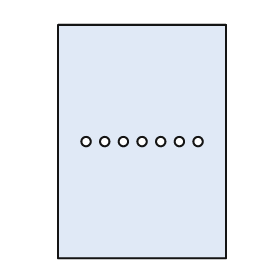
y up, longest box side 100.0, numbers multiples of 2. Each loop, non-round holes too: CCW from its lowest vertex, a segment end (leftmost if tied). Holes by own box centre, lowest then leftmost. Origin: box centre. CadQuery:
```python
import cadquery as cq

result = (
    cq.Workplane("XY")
    .moveTo(-36.0, -50.0)
    .lineTo(36.0, -50.0)
    .lineTo(36.0, 50.0)
    .lineTo(-36.0, 50.0)
    .close()
    .moveTo(-24.0, 0.0)
    .circle(2.0)
    .moveTo(-16.0, 0.0)
    .circle(2.0)
    .moveTo(-8.0, 0.0)
    .circle(2.0)
    .moveTo(0.0, 0.0)
    .circle(2.0)
    .moveTo(8.0, 0.0)
    .circle(2.0)
    .moveTo(16.0, 0.0)
    .circle(2.0)
    .moveTo(24.0, 0.0)
    .circle(2.0)
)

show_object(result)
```